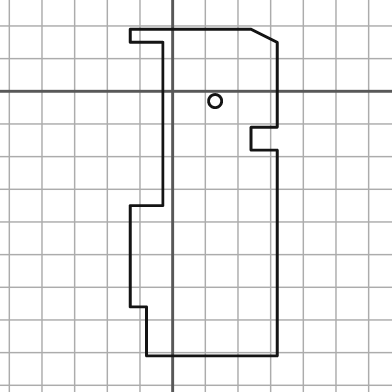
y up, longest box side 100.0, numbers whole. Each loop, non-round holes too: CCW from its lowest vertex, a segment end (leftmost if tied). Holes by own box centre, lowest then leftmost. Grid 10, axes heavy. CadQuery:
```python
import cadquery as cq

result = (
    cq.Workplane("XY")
    .moveTo(-8.0, -81.0)
    .lineTo(32.0, -81.0)
    .lineTo(32.0, -18.0)
    .lineTo(24.0, -18.0)
    .lineTo(24.0, -11.0)
    .lineTo(32.0, -11.0)
    .lineTo(32.0, 15.0)
    .lineTo(24.0, 19.0)
    .lineTo(-13.0, 19.0)
    .lineTo(-13.0, 15.0)
    .lineTo(-3.0, 15.0)
    .lineTo(-3.0, -35.0)
    .lineTo(-13.0, -35.0)
    .lineTo(-13.0, -66.0)
    .lineTo(-8.0, -66.0)
    .close()
    .moveTo(13.0, -3.0)
    .circle(2.0)
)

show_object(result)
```